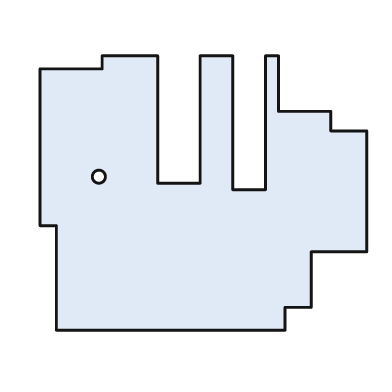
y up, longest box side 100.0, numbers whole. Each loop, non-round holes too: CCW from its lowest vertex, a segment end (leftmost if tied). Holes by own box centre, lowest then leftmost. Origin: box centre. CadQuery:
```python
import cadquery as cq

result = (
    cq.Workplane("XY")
    .moveTo(-45.0, -42.0)
    .lineTo(25.0, -42.0)
    .lineTo(25.0, -35.0)
    .lineTo(33.0, -35.0)
    .lineTo(33.0, -18.0)
    .lineTo(50.0, -18.0)
    .lineTo(50.0, 19.0)
    .lineTo(39.0, 19.0)
    .lineTo(39.0, 25.0)
    .lineTo(23.0, 25.0)
    .lineTo(23.0, 42.0)
    .lineTo(19.0, 42.0)
    .lineTo(19.0, 1.0)
    .lineTo(9.0, 1.0)
    .lineTo(9.0, 42.0)
    .lineTo(-1.0, 42.0)
    .lineTo(-1.0, 3.0)
    .lineTo(-14.0, 3.0)
    .lineTo(-14.0, 42.0)
    .lineTo(-31.0, 42.0)
    .lineTo(-31.0, 38.0)
    .lineTo(-50.0, 38.0)
    .lineTo(-50.0, -10.0)
    .lineTo(-45.0, -10.0)
    .close()
    .moveTo(-32.0, 5.0)
    .circle(2.0)
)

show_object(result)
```